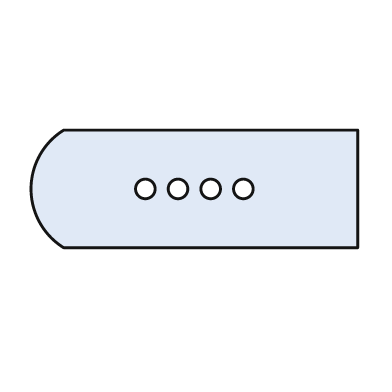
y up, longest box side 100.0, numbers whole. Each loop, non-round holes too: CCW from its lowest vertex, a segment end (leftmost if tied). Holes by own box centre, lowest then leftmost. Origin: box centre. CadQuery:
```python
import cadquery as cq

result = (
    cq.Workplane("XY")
    .moveTo(-40.0, -18.0)
    .lineTo(50.0, -18.0)
    .lineTo(50.0, 18.0)
    .lineTo(-40.0, 18.0)
    .threePointArc((-50.0, 0.0), (-40.0, -18.0))
    .close()
    .moveTo(-15.0, 0.0)
    .circle(3.0)
    .moveTo(-5.0, 0.0)
    .circle(3.0)
    .moveTo(5.0, 0.0)
    .circle(3.0)
    .moveTo(15.0, 0.0)
    .circle(3.0)
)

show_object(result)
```